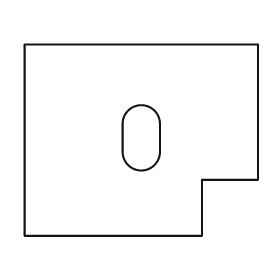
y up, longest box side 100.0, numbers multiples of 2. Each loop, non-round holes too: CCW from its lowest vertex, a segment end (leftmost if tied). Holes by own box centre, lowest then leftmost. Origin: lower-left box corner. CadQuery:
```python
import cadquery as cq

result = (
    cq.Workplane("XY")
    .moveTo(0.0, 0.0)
    .lineTo(76.0, 0.0)
    .lineTo(76.0, 24.0)
    .lineTo(100.0, 24.0)
    .lineTo(100.0, 82.0)
    .lineTo(0.0, 82.0)
    .close()
    .moveTo(42.0, 36.0)
    .threePointArc((50.0, 28.0), (58.0, 36.0))
    .lineTo(58.0, 48.0)
    .threePointArc((50.0, 56.0), (42.0, 48.0))
    .close()
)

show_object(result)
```